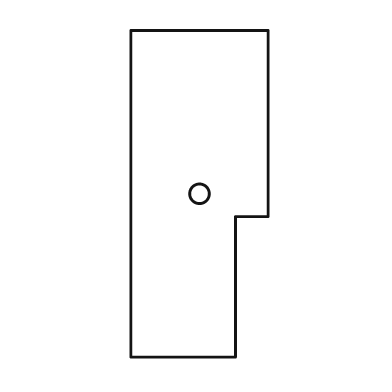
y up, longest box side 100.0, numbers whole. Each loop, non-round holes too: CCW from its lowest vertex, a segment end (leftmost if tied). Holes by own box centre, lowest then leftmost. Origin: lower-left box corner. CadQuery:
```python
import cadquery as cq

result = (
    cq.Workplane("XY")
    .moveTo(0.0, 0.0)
    .lineTo(32.0, 0.0)
    .lineTo(32.0, 43.0)
    .lineTo(42.0, 43.0)
    .lineTo(42.0, 100.0)
    .lineTo(0.0, 100.0)
    .close()
    .moveTo(21.0, 50.0)
    .circle(3.0)
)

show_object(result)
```